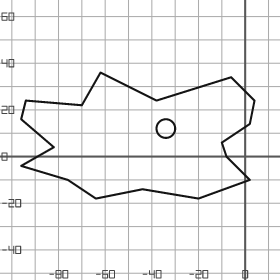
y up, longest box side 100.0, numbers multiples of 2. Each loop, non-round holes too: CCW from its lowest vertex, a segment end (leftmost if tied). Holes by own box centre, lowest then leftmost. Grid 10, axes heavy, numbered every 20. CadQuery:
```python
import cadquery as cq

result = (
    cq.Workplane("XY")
    .moveTo(-64.0, -18.0)
    .lineTo(-44.0, -14.0)
    .lineTo(-20.0, -18.0)
    .lineTo(2.0, -10.0)
    .lineTo(-8.0, 0.0)
    .lineTo(-10.0, 6.0)
    .lineTo(2.0, 14.0)
    .lineTo(4.0, 24.0)
    .lineTo(-6.0, 34.0)
    .lineTo(-38.0, 24.0)
    .lineTo(-62.0, 36.0)
    .lineTo(-70.0, 22.0)
    .lineTo(-94.0, 24.0)
    .lineTo(-96.0, 16.0)
    .lineTo(-82.0, 4.0)
    .lineTo(-96.0, -4.0)
    .lineTo(-76.0, -10.0)
    .close()
    .moveTo(-34.0, 12.0)
    .circle(4.0)
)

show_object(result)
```